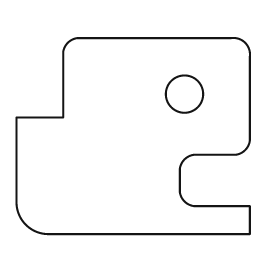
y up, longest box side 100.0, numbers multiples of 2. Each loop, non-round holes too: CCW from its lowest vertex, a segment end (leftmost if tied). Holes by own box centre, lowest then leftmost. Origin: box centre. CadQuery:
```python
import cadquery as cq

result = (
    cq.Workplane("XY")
    .moveTo(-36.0, -42.0)
    .lineTo(50.0, -42.0)
    .lineTo(50.0, -30.0)
    .lineTo(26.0, -30.0)
    .threePointArc((22.0, -28.0), (20.0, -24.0))
    .lineTo(20.0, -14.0)
    .threePointArc((22.0, -10.0), (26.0, -8.0))
    .lineTo(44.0, -8.0)
    .threePointArc((48.0, -6.0), (50.0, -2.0))
    .lineTo(50.0, 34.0)
    .threePointArc((48.0, 40.0), (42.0, 42.0))
    .lineTo(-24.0, 42.0)
    .threePointArc((-28.0, 40.0), (-30.0, 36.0))
    .lineTo(-30.0, 8.0)
    .lineTo(-50.0, 8.0)
    .lineTo(-50.0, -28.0)
    .threePointArc((-46.0, -38.0), (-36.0, -42.0))
    .close()
    .moveTo(22.0, 18.0)
    .circle(8.0)
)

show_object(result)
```